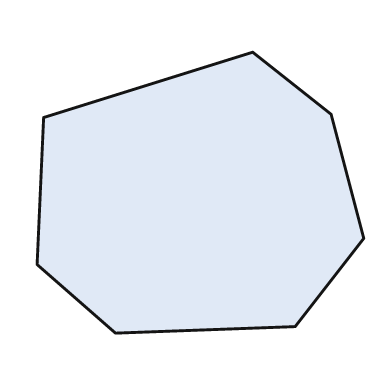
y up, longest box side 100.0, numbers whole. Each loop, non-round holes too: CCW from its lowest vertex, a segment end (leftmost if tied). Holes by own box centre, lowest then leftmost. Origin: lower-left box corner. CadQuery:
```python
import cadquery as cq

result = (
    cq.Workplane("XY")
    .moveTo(24.0, 0.0)
    .lineTo(79.0, 2.0)
    .lineTo(100.0, 29.0)
    .lineTo(90.0, 67.0)
    .lineTo(66.0, 86.0)
    .lineTo(2.0, 66.0)
    .lineTo(0.0, 21.0)
    .close()
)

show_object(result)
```